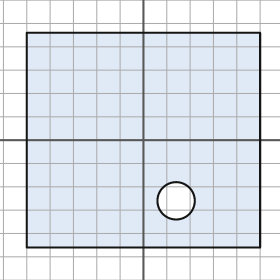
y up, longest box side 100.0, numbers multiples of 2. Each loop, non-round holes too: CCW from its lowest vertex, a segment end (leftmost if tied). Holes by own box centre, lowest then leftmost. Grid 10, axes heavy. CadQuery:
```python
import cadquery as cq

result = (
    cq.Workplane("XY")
    .moveTo(-50.0, -46.0)
    .lineTo(50.0, -46.0)
    .lineTo(50.0, 46.0)
    .lineTo(-50.0, 46.0)
    .close()
    .moveTo(14.0, -26.0)
    .circle(8.0)
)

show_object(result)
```